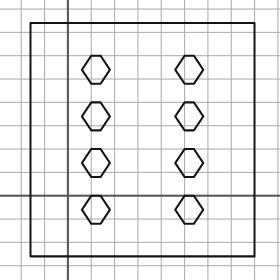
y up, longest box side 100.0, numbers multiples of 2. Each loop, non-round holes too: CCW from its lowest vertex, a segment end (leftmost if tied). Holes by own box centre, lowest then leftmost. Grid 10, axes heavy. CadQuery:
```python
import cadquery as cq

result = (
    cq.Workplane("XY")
    .moveTo(-16.0, -26.0)
    .lineTo(80.0, -26.0)
    .lineTo(80.0, 74.0)
    .lineTo(-16.0, 74.0)
    .close()
    .moveTo(10.0, -12.0)
    .lineTo(14.0, -12.0)
    .lineTo(18.0, -6.0)
    .lineTo(14.0, 0.0)
    .lineTo(10.0, 0.0)
    .lineTo(6.0, -6.0)
    .close()
    .moveTo(50.0, -12.0)
    .lineTo(54.0, -12.0)
    .lineTo(58.0, -6.0)
    .lineTo(54.0, 0.0)
    .lineTo(50.0, 0.0)
    .lineTo(46.0, -6.0)
    .close()
    .moveTo(10.0, 8.0)
    .lineTo(14.0, 8.0)
    .lineTo(18.0, 14.0)
    .lineTo(14.0, 20.0)
    .lineTo(10.0, 20.0)
    .lineTo(6.0, 14.0)
    .close()
    .moveTo(50.0, 8.0)
    .lineTo(54.0, 8.0)
    .lineTo(58.0, 14.0)
    .lineTo(54.0, 20.0)
    .lineTo(50.0, 20.0)
    .lineTo(46.0, 14.0)
    .close()
    .moveTo(10.0, 28.0)
    .lineTo(14.0, 28.0)
    .lineTo(18.0, 34.0)
    .lineTo(14.0, 40.0)
    .lineTo(10.0, 40.0)
    .lineTo(6.0, 34.0)
    .close()
    .moveTo(50.0, 28.0)
    .lineTo(54.0, 28.0)
    .lineTo(58.0, 34.0)
    .lineTo(54.0, 40.0)
    .lineTo(50.0, 40.0)
    .lineTo(46.0, 34.0)
    .close()
    .moveTo(10.0, 48.0)
    .lineTo(14.0, 48.0)
    .lineTo(18.0, 54.0)
    .lineTo(14.0, 60.0)
    .lineTo(10.0, 60.0)
    .lineTo(6.0, 54.0)
    .close()
    .moveTo(50.0, 48.0)
    .lineTo(54.0, 48.0)
    .lineTo(58.0, 54.0)
    .lineTo(54.0, 60.0)
    .lineTo(50.0, 60.0)
    .lineTo(46.0, 54.0)
    .close()
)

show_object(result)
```